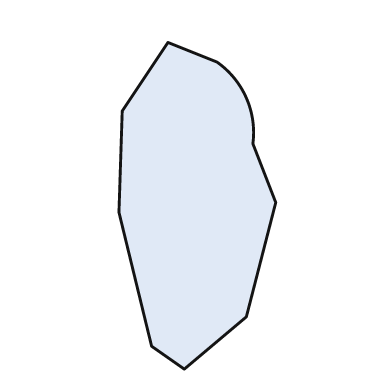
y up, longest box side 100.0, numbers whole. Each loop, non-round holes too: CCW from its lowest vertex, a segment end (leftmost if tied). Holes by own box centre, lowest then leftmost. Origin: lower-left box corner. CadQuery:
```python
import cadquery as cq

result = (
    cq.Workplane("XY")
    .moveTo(20.0, 0.0)
    .lineTo(39.0, 16.0)
    .lineTo(48.0, 51.0)
    .lineTo(41.0, 69.0)
    .threePointArc((39.0, 83.0), (30.0, 94.0))
    .lineTo(15.0, 100.0)
    .lineTo(1.0, 79.0)
    .lineTo(0.0, 48.0)
    .lineTo(10.0, 7.0)
    .close()
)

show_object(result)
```